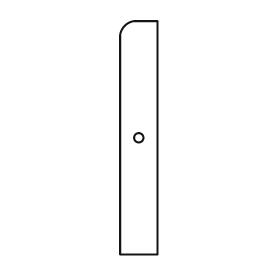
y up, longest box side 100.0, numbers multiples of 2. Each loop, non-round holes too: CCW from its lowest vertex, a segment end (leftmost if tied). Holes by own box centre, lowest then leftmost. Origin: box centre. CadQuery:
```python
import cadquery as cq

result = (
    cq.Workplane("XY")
    .moveTo(-8.0, -50.0)
    .lineTo(8.0, -50.0)
    .lineTo(8.0, 50.0)
    .lineTo(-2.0, 50.0)
    .threePointArc((-6.0, 48.0), (-8.0, 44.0))
    .close()
    .moveTo(0.0, 0.0)
    .circle(2.0)
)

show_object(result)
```